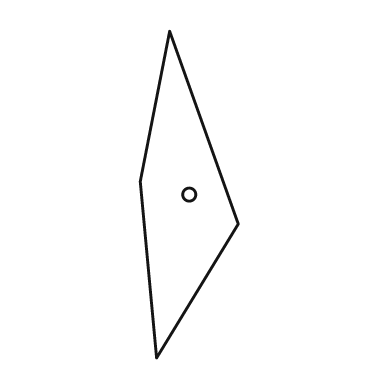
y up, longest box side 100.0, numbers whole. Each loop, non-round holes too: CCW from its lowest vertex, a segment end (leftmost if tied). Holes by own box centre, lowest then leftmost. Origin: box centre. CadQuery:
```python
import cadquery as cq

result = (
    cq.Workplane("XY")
    .moveTo(-10.0, -50.0)
    .lineTo(15.0, -9.0)
    .lineTo(-6.0, 50.0)
    .lineTo(-15.0, 4.0)
    .close()
    .moveTo(0.0, 0.0)
    .circle(2.0)
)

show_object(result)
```